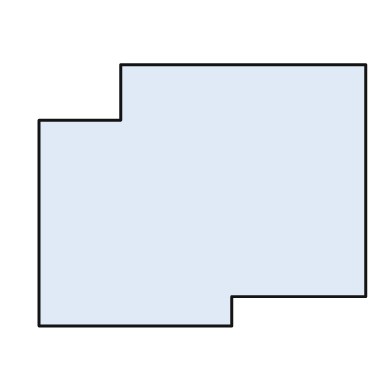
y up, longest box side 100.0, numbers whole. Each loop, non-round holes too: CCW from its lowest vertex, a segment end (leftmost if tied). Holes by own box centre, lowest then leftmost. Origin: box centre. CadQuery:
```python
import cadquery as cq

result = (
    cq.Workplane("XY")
    .moveTo(-50.0, -40.0)
    .lineTo(9.0, -40.0)
    .lineTo(9.0, -31.0)
    .lineTo(50.0, -31.0)
    .lineTo(50.0, 40.0)
    .lineTo(-25.0, 40.0)
    .lineTo(-25.0, 23.0)
    .lineTo(-50.0, 23.0)
    .close()
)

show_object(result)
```